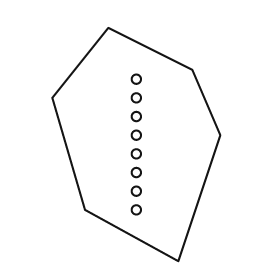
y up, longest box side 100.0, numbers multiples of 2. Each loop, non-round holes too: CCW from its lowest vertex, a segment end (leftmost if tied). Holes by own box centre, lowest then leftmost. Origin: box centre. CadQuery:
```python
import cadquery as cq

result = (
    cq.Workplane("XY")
    .moveTo(18.0, -50.0)
    .lineTo(36.0, 4.0)
    .lineTo(24.0, 32.0)
    .lineTo(-12.0, 50.0)
    .lineTo(-36.0, 20.0)
    .lineTo(-22.0, -28.0)
    .close()
    .moveTo(0.0, -28.0)
    .circle(2.0)
    .moveTo(0.0, -20.0)
    .circle(2.0)
    .moveTo(0.0, -12.0)
    .circle(2.0)
    .moveTo(0.0, -4.0)
    .circle(2.0)
    .moveTo(0.0, 4.0)
    .circle(2.0)
    .moveTo(0.0, 12.0)
    .circle(2.0)
    .moveTo(0.0, 20.0)
    .circle(2.0)
    .moveTo(0.0, 28.0)
    .circle(2.0)
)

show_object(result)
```